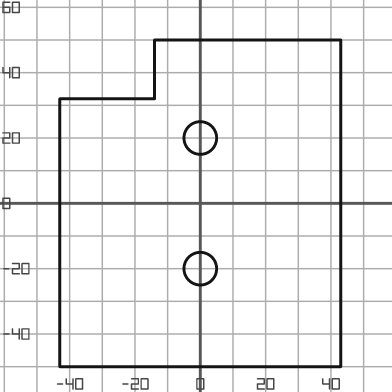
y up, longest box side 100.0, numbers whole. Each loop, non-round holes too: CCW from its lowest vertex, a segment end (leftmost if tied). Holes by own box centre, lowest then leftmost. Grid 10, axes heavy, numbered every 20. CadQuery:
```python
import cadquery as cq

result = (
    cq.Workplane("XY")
    .moveTo(-43.0, -50.0)
    .lineTo(43.0, -50.0)
    .lineTo(43.0, 50.0)
    .lineTo(-14.0, 50.0)
    .lineTo(-14.0, 32.0)
    .lineTo(-43.0, 32.0)
    .close()
    .moveTo(0.0, -20.0)
    .circle(5.0)
    .moveTo(0.0, 20.0)
    .circle(5.0)
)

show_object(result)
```